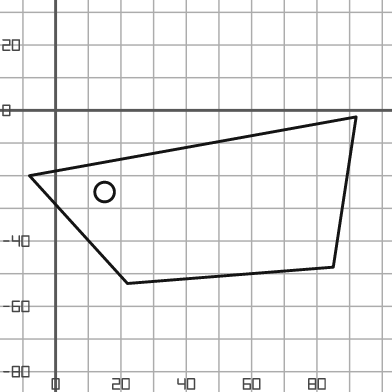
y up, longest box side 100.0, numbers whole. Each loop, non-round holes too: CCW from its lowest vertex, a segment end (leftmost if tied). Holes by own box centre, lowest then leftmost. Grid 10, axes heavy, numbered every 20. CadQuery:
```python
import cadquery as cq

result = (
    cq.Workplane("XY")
    .moveTo(22.0, -53.0)
    .lineTo(85.0, -48.0)
    .lineTo(92.0, -2.0)
    .lineTo(-8.0, -20.0)
    .close()
    .moveTo(15.0, -25.0)
    .circle(3.0)
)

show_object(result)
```